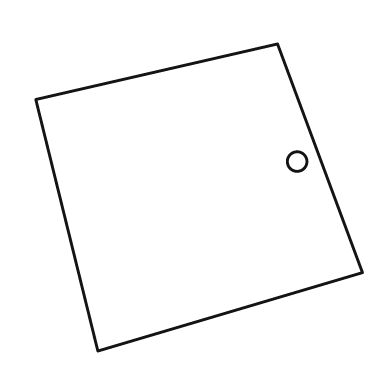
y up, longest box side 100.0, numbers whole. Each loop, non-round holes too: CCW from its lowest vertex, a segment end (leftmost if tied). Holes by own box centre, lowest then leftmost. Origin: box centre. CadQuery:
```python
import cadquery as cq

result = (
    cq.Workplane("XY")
    .moveTo(-31.0, -47.0)
    .lineTo(50.0, -23.0)
    .lineTo(24.0, 47.0)
    .lineTo(-50.0, 30.0)
    .close()
    .moveTo(30.0, 11.0)
    .circle(3.0)
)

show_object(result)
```